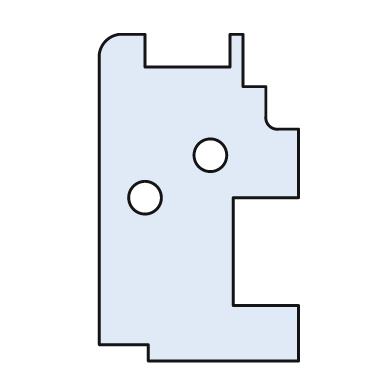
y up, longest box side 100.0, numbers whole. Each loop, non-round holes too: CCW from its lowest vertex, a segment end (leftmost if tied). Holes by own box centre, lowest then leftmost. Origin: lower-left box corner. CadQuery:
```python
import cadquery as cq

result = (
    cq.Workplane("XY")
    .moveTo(15.0, 0.0)
    .lineTo(61.0, 0.0)
    .lineTo(61.0, 17.0)
    .lineTo(41.0, 17.0)
    .lineTo(41.0, 50.0)
    .lineTo(61.0, 50.0)
    .lineTo(61.0, 71.0)
    .lineTo(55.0, 71.0)
    .threePointArc((52.0, 72.0), (51.0, 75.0))
    .lineTo(51.0, 84.0)
    .lineTo(44.0, 84.0)
    .lineTo(44.0, 100.0)
    .lineTo(40.0, 100.0)
    .lineTo(40.0, 90.0)
    .lineTo(14.0, 90.0)
    .lineTo(14.0, 100.0)
    .lineTo(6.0, 100.0)
    .threePointArc((2.0, 98.0), (0.0, 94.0))
    .lineTo(0.0, 5.0)
    .lineTo(15.0, 5.0)
    .close()
    .moveTo(14.0, 50.0)
    .circle(5.0)
    .moveTo(34.0, 63.0)
    .circle(5.0)
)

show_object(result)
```